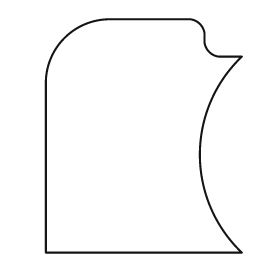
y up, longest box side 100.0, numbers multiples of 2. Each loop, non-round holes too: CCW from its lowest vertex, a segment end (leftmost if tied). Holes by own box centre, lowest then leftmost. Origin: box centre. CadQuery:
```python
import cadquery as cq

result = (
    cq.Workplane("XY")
    .moveTo(-42.0, -50.0)
    .lineTo(42.0, -50.0)
    .threePointArc((24.0, -8.0), (42.0, 34.0))
    .lineTo(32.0, 34.0)
    .threePointArc((28.0, 36.0), (26.0, 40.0))
    .lineTo(26.0, 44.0)
    .threePointArc((24.0, 48.0), (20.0, 50.0))
    .lineTo(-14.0, 50.0)
    .threePointArc((-34.0, 42.0), (-42.0, 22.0))
    .close()
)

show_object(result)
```